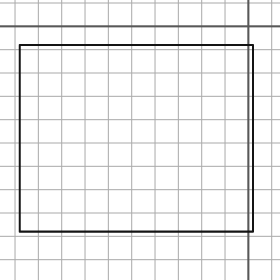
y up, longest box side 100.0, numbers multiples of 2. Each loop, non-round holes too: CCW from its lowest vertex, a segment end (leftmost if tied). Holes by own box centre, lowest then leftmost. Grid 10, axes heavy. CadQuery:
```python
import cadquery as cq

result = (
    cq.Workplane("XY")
    .moveTo(-98.0, -88.0)
    .lineTo(2.0, -88.0)
    .lineTo(2.0, -8.0)
    .lineTo(-98.0, -8.0)
    .close()
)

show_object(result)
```